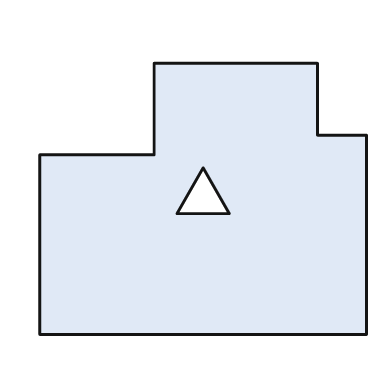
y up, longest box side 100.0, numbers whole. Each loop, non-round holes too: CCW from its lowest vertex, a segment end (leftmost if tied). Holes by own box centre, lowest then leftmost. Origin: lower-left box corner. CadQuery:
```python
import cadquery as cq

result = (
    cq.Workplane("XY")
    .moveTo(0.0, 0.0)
    .lineTo(100.0, 0.0)
    .lineTo(100.0, 61.0)
    .lineTo(85.0, 61.0)
    .lineTo(85.0, 83.0)
    .lineTo(35.0, 83.0)
    .lineTo(35.0, 55.0)
    .lineTo(0.0, 55.0)
    .close()
    .moveTo(42.0, 37.0)
    .lineTo(58.0, 37.0)
    .lineTo(50.0, 51.0)
    .close()
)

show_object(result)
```